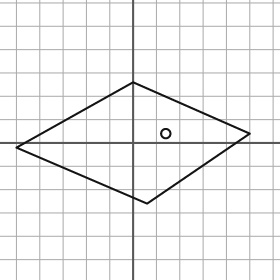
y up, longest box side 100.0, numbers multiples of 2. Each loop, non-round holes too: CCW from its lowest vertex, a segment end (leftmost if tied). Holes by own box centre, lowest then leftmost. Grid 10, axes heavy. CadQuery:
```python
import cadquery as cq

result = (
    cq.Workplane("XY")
    .moveTo(6.0, -26.0)
    .lineTo(50.0, 4.0)
    .lineTo(0.0, 26.0)
    .lineTo(-50.0, -2.0)
    .close()
    .moveTo(14.0, 4.0)
    .circle(2.0)
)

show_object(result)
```